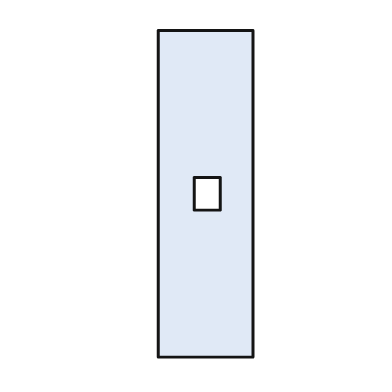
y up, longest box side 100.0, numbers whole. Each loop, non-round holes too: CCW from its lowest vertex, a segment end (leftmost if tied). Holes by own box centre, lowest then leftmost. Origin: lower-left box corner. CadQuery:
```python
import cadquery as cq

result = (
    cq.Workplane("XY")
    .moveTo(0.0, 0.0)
    .lineTo(29.0, 0.0)
    .lineTo(29.0, 100.0)
    .lineTo(0.0, 100.0)
    .close()
    .moveTo(11.0, 45.0)
    .lineTo(19.0, 45.0)
    .lineTo(19.0, 55.0)
    .lineTo(11.0, 55.0)
    .close()
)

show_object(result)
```